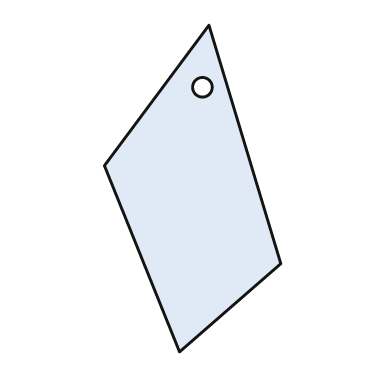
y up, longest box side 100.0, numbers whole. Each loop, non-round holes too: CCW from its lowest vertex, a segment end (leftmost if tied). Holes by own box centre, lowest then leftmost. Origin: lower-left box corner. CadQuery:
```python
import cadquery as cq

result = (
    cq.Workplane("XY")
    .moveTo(23.0, 0.0)
    .lineTo(54.0, 27.0)
    .lineTo(32.0, 100.0)
    .lineTo(0.0, 57.0)
    .close()
    .moveTo(30.0, 81.0)
    .circle(3.0)
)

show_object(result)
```